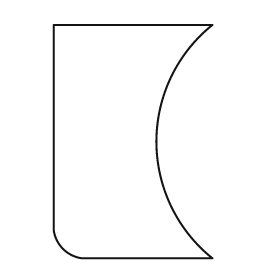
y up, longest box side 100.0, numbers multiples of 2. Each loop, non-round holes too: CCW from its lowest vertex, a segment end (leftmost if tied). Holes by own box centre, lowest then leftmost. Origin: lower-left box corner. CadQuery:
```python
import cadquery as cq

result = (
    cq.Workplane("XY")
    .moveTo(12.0, 0.0)
    .lineTo(68.0, 0.0)
    .threePointArc((44.0, 50.0), (68.0, 100.0))
    .lineTo(0.0, 100.0)
    .lineTo(0.0, 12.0)
    .threePointArc((4.0, 4.0), (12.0, 0.0))
    .close()
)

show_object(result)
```